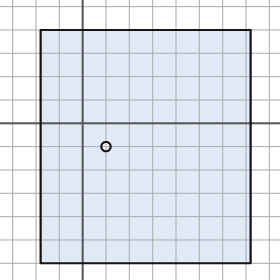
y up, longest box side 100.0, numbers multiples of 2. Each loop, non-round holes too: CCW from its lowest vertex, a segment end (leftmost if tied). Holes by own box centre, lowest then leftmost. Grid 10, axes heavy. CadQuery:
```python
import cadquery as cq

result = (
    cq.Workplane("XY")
    .moveTo(-18.0, -60.0)
    .lineTo(72.0, -60.0)
    .lineTo(72.0, 40.0)
    .lineTo(-18.0, 40.0)
    .close()
    .moveTo(10.0, -10.0)
    .circle(2.0)
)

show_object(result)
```